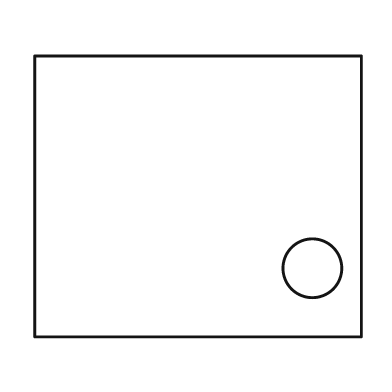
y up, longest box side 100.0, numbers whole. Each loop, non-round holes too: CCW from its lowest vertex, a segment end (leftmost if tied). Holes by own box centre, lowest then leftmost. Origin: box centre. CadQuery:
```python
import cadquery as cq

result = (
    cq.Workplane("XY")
    .moveTo(-50.0, -43.0)
    .lineTo(50.0, -43.0)
    .lineTo(50.0, 43.0)
    .lineTo(-50.0, 43.0)
    .close()
    .moveTo(35.0, -22.0)
    .circle(9.0)
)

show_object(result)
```